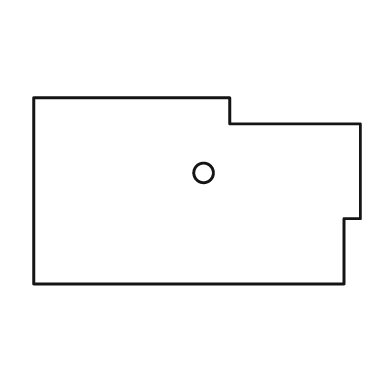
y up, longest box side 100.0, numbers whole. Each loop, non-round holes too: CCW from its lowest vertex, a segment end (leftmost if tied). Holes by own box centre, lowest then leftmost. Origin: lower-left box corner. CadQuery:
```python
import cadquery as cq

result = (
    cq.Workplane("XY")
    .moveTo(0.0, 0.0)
    .lineTo(95.0, 0.0)
    .lineTo(95.0, 20.0)
    .lineTo(100.0, 20.0)
    .lineTo(100.0, 49.0)
    .lineTo(60.0, 49.0)
    .lineTo(60.0, 57.0)
    .lineTo(0.0, 57.0)
    .close()
    .moveTo(52.0, 34.0)
    .circle(3.0)
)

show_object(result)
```